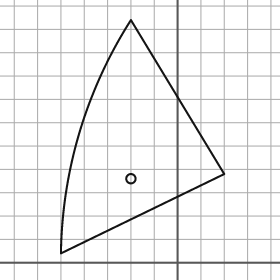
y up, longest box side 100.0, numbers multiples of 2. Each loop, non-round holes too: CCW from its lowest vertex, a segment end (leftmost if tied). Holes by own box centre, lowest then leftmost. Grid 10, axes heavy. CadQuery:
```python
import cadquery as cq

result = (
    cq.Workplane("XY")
    .moveTo(-50.0, 4.0)
    .lineTo(20.0, 38.0)
    .lineTo(-20.0, 104.0)
    .threePointArc((-42.0, 56.0), (-50.0, 4.0))
    .close()
    .moveTo(-20.0, 36.0)
    .circle(2.0)
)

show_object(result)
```